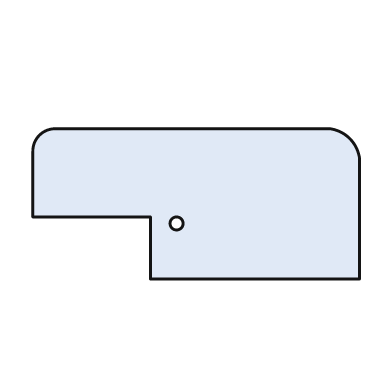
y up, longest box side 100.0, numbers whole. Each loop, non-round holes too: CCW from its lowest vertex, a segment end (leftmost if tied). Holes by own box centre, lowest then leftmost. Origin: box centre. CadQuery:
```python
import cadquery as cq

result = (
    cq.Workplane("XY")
    .moveTo(-14.0, -23.0)
    .lineTo(50.0, -23.0)
    .lineTo(50.0, 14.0)
    .threePointArc((47.0, 20.0), (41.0, 23.0))
    .lineTo(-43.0, 23.0)
    .threePointArc((-48.0, 21.0), (-50.0, 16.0))
    .lineTo(-50.0, -4.0)
    .lineTo(-14.0, -4.0)
    .close()
    .moveTo(-6.0, -6.0)
    .circle(2.0)
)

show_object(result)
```